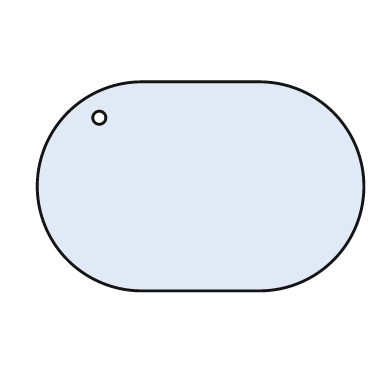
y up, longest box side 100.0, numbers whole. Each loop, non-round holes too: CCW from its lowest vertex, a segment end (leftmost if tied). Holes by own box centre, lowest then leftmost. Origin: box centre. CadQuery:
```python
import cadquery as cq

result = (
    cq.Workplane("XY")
    .moveTo(-18.0, -32.0)
    .lineTo(18.0, -32.0)
    .threePointArc((50.0, 0.0), (18.0, 32.0))
    .lineTo(-18.0, 32.0)
    .threePointArc((-50.0, 0.0), (-18.0, -32.0))
    .close()
    .moveTo(-31.0, 21.0)
    .circle(2.0)
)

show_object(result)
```